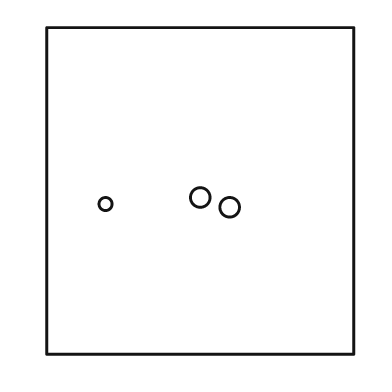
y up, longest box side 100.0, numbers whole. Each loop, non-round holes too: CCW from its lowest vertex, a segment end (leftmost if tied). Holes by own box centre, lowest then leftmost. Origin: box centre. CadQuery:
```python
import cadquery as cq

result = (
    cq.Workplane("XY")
    .moveTo(-47.0, -50.0)
    .lineTo(47.0, -50.0)
    .lineTo(47.0, 50.0)
    .lineTo(-47.0, 50.0)
    .close()
    .moveTo(9.0, -5.0)
    .circle(3.0)
    .moveTo(-29.0, -4.0)
    .circle(2.0)
    .moveTo(0.0, -2.0)
    .circle(3.0)
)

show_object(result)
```